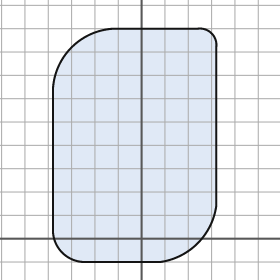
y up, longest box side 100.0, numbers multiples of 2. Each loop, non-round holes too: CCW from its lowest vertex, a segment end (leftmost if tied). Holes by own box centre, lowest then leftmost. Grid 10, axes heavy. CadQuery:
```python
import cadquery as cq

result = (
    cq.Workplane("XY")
    .moveTo(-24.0, -10.0)
    .lineTo(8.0, -10.0)
    .threePointArc((24.0, -2.0), (32.0, 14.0))
    .lineTo(32.0, 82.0)
    .threePointArc((30.0, 88.0), (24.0, 90.0))
    .lineTo(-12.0, 90.0)
    .threePointArc((-30.0, 82.0), (-38.0, 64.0))
    .lineTo(-38.0, 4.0)
    .threePointArc((-34.0, -6.0), (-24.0, -10.0))
    .close()
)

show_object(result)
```